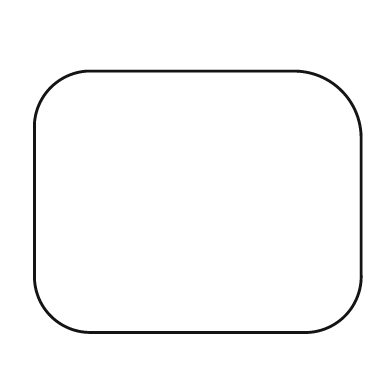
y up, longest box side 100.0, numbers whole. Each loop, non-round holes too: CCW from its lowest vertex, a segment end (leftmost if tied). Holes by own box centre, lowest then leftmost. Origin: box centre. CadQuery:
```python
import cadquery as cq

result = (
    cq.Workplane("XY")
    .moveTo(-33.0, -40.0)
    .lineTo(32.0, -40.0)
    .threePointArc((45.0, -35.0), (50.0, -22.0))
    .lineTo(50.0, 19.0)
    .threePointArc((44.0, 34.0), (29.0, 40.0))
    .lineTo(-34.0, 40.0)
    .threePointArc((-45.0, 35.0), (-50.0, 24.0))
    .lineTo(-50.0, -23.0)
    .threePointArc((-45.0, -35.0), (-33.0, -40.0))
    .close()
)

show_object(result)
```